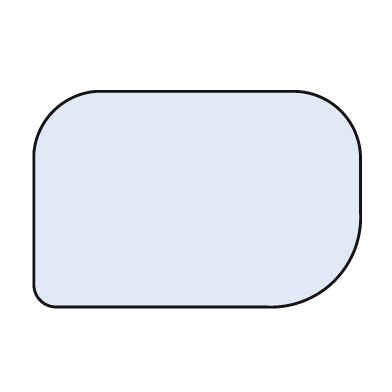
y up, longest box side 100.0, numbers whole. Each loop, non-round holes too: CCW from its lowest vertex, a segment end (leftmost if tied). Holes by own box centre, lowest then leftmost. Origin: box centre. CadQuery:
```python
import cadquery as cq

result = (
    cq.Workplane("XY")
    .moveTo(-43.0, -33.0)
    .lineTo(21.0, -33.0)
    .threePointArc((42.0, -25.0), (50.0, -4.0))
    .lineTo(50.0, 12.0)
    .threePointArc((44.0, 27.0), (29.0, 33.0))
    .lineTo(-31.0, 33.0)
    .threePointArc((-44.0, 27.0), (-50.0, 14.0))
    .lineTo(-50.0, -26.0)
    .threePointArc((-48.0, -31.0), (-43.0, -33.0))
    .close()
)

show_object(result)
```